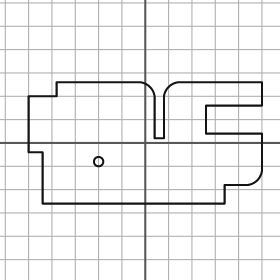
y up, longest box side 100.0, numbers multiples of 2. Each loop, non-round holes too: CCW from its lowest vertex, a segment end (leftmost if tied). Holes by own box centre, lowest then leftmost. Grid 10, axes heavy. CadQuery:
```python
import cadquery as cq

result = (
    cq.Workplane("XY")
    .moveTo(-44.0, -26.0)
    .lineTo(34.0, -26.0)
    .lineTo(34.0, -18.0)
    .lineTo(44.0, -18.0)
    .threePointArc((48.0, -16.0), (50.0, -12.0))
    .lineTo(50.0, 4.0)
    .lineTo(26.0, 4.0)
    .lineTo(26.0, 16.0)
    .lineTo(50.0, 16.0)
    .lineTo(50.0, 26.0)
    .lineTo(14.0, 26.0)
    .threePointArc((10.0, 24.0), (8.0, 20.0))
    .lineTo(8.0, 2.0)
    .lineTo(4.0, 2.0)
    .lineTo(4.0, 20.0)
    .threePointArc((2.0, 24.0), (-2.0, 26.0))
    .lineTo(-38.0, 26.0)
    .lineTo(-38.0, 20.0)
    .lineTo(-50.0, 20.0)
    .lineTo(-50.0, -4.0)
    .lineTo(-44.0, -4.0)
    .close()
    .moveTo(-20.0, -8.0)
    .circle(2.0)
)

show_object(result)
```